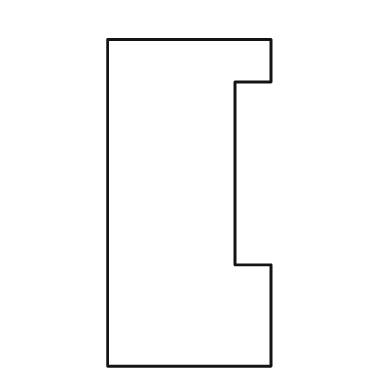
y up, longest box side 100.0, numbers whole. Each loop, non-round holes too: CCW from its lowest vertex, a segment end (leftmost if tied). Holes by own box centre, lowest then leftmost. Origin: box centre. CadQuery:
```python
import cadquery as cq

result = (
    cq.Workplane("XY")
    .moveTo(-25.0, -50.0)
    .lineTo(25.0, -50.0)
    .lineTo(25.0, -19.0)
    .lineTo(14.0, -19.0)
    .lineTo(14.0, 37.0)
    .lineTo(25.0, 37.0)
    .lineTo(25.0, 50.0)
    .lineTo(-25.0, 50.0)
    .close()
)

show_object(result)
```